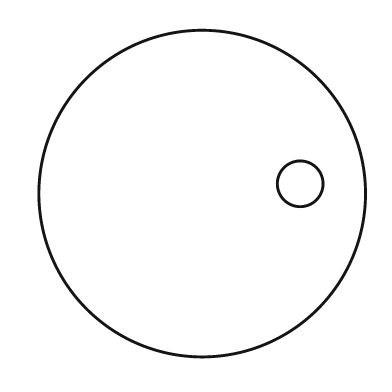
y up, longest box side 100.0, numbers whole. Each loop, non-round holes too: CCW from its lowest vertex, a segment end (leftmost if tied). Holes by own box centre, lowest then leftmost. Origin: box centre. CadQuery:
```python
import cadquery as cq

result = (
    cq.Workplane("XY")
    .moveTo(0.0, 0.0)
    .circle(50.0)
    .moveTo(30.0, 3.0)
    .circle(7.0)
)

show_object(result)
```